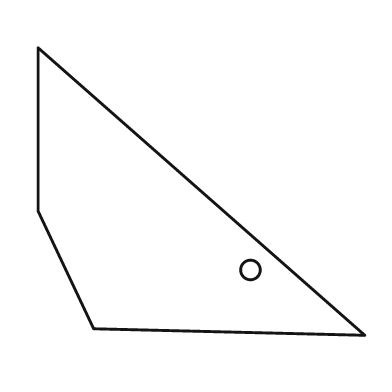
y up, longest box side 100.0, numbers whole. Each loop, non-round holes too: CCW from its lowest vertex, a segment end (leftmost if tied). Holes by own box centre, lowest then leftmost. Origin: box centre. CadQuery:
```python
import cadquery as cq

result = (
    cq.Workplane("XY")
    .moveTo(50.0, -44.0)
    .lineTo(-50.0, 44.0)
    .lineTo(-50.0, -6.0)
    .lineTo(-33.0, -42.0)
    .close()
    .moveTo(15.0, -24.0)
    .circle(3.0)
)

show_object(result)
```